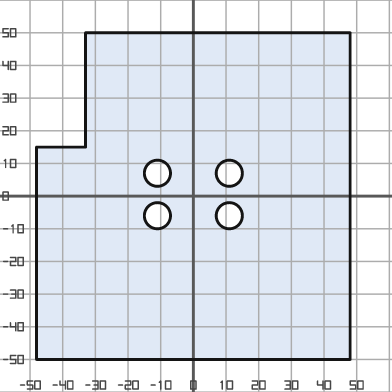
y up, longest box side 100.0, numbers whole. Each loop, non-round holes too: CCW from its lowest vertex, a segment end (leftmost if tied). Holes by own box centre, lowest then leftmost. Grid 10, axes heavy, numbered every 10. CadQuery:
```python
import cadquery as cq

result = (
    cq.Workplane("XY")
    .moveTo(-48.0, -50.0)
    .lineTo(48.0, -50.0)
    .lineTo(48.0, 50.0)
    .lineTo(-33.0, 50.0)
    .lineTo(-33.0, 15.0)
    .lineTo(-48.0, 15.0)
    .close()
    .moveTo(-11.0, -6.0)
    .circle(4.0)
    .moveTo(11.0, -6.0)
    .circle(4.0)
    .moveTo(-11.0, 7.0)
    .circle(4.0)
    .moveTo(11.0, 7.0)
    .circle(4.0)
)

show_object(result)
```